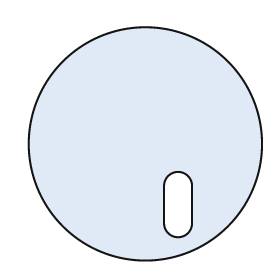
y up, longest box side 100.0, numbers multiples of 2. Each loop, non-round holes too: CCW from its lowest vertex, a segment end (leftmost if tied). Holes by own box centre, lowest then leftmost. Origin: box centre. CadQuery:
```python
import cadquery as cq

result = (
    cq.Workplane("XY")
    .moveTo(0.0, 0.0)
    .circle(50.0)
    .moveTo(8.0, -34.0)
    .threePointArc((14.0, -40.0), (20.0, -34.0))
    .lineTo(20.0, -18.0)
    .threePointArc((14.0, -12.0), (8.0, -18.0))
    .close()
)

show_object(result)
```